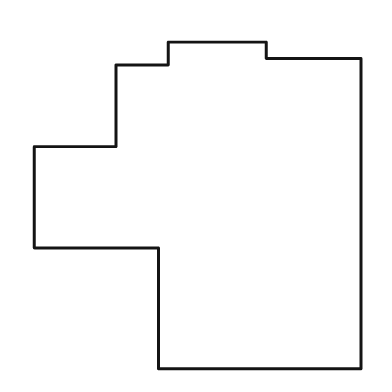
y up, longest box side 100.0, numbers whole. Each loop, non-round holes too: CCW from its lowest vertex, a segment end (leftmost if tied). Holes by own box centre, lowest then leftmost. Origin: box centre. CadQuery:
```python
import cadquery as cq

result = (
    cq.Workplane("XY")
    .moveTo(-12.0, -50.0)
    .lineTo(50.0, -50.0)
    .lineTo(50.0, 45.0)
    .lineTo(21.0, 45.0)
    .lineTo(21.0, 50.0)
    .lineTo(-9.0, 50.0)
    .lineTo(-9.0, 43.0)
    .lineTo(-25.0, 43.0)
    .lineTo(-25.0, 18.0)
    .lineTo(-50.0, 18.0)
    .lineTo(-50.0, -13.0)
    .lineTo(-12.0, -13.0)
    .close()
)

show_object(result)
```